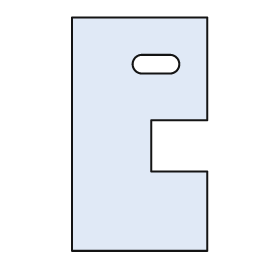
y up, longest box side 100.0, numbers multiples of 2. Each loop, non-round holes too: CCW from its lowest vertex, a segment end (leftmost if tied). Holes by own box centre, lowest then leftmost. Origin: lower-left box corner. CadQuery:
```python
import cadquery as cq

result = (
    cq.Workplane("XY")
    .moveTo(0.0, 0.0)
    .lineTo(58.0, 0.0)
    .lineTo(58.0, 34.0)
    .lineTo(34.0, 34.0)
    .lineTo(34.0, 56.0)
    .lineTo(58.0, 56.0)
    .lineTo(58.0, 100.0)
    .lineTo(0.0, 100.0)
    .close()
    .moveTo(30.0, 76.0)
    .lineTo(42.0, 76.0)
    .threePointArc((46.0, 80.0), (42.0, 84.0))
    .lineTo(30.0, 84.0)
    .threePointArc((26.0, 80.0), (30.0, 76.0))
    .close()
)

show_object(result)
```